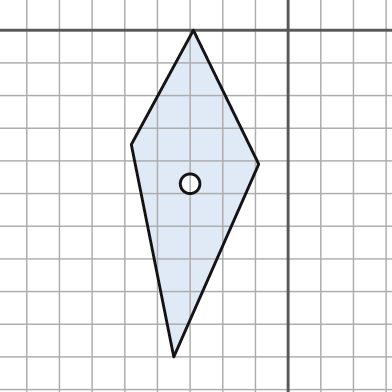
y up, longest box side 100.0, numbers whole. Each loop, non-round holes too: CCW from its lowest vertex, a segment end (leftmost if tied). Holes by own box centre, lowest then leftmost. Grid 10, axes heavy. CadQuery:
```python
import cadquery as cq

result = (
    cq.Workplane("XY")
    .moveTo(-35.0, -100.0)
    .lineTo(-9.0, -41.0)
    .lineTo(-29.0, 0.0)
    .lineTo(-48.0, -35.0)
    .close()
    .moveTo(-30.0, -47.0)
    .circle(3.0)
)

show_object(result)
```